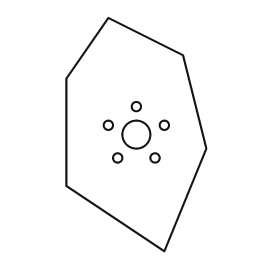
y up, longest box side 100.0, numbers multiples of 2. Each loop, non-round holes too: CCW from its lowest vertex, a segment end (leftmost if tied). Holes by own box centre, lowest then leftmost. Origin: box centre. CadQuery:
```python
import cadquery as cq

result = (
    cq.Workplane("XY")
    .moveTo(12.0, -50.0)
    .lineTo(30.0, -6.0)
    .lineTo(20.0, 34.0)
    .lineTo(-12.0, 50.0)
    .lineTo(-30.0, 24.0)
    .lineTo(-30.0, -22.0)
    .close()
    .moveTo(-8.0, -10.0)
    .circle(2.0)
    .moveTo(8.0, -10.0)
    .circle(2.0)
    .moveTo(0.0, 0.0)
    .circle(6.0)
    .moveTo(-12.0, 4.0)
    .circle(2.0)
    .moveTo(12.0, 4.0)
    .circle(2.0)
    .moveTo(0.0, 12.0)
    .circle(2.0)
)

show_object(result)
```